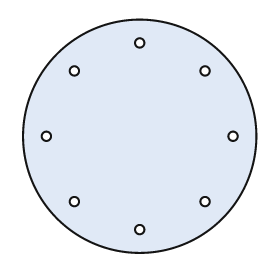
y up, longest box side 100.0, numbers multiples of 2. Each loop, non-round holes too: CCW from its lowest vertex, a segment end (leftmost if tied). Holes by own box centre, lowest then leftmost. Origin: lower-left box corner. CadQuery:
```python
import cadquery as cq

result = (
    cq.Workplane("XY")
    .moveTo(50.0, 50.0)
    .circle(50.0)
    .moveTo(50.0, 10.0)
    .circle(2.0)
    .moveTo(22.0, 22.0)
    .circle(2.0)
    .moveTo(78.0, 22.0)
    .circle(2.0)
    .moveTo(10.0, 50.0)
    .circle(2.0)
    .moveTo(90.0, 50.0)
    .circle(2.0)
    .moveTo(22.0, 78.0)
    .circle(2.0)
    .moveTo(78.0, 78.0)
    .circle(2.0)
    .moveTo(50.0, 90.0)
    .circle(2.0)
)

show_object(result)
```